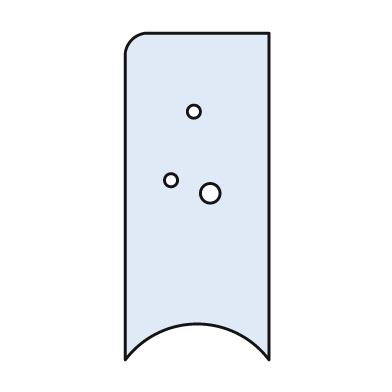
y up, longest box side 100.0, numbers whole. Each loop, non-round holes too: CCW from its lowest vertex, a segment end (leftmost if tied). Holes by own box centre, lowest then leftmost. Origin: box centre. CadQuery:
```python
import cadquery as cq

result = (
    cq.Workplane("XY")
    .moveTo(-22.0, -50.0)
    .threePointArc((0.0, -39.0), (22.0, -50.0))
    .lineTo(22.0, 50.0)
    .lineTo(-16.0, 50.0)
    .threePointArc((-20.0, 48.0), (-22.0, 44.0))
    .close()
    .moveTo(4.0, 1.0)
    .circle(3.0)
    .moveTo(-8.0, 5.0)
    .circle(2.0)
    .moveTo(-1.0, 26.0)
    .circle(2.0)
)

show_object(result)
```